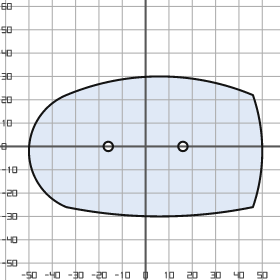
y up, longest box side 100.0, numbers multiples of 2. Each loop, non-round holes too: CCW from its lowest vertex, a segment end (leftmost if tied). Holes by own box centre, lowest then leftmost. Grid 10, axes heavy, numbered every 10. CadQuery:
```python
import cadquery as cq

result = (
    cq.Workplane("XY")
    .moveTo(-34.0, -26.0)
    .threePointArc((6.0, -30.0), (46.0, -26.0))
    .threePointArc((50.0, -2.0), (46.0, 22.0))
    .threePointArc((6.0, 30.0), (-34.0, 22.0))
    .threePointArc((-50.0, -2.0), (-34.0, -26.0))
    .close()
    .moveTo(-16.0, 0.0)
    .circle(2.0)
    .moveTo(16.0, 0.0)
    .circle(2.0)
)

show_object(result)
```